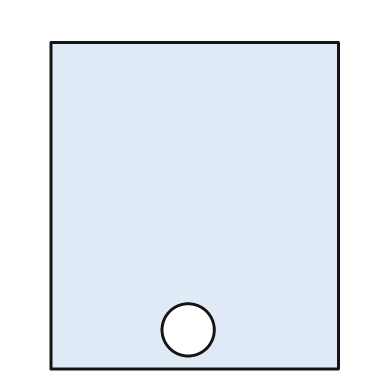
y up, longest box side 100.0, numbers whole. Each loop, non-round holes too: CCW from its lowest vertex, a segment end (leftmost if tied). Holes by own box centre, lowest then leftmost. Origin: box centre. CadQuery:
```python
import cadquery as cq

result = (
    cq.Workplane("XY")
    .moveTo(-44.0, -50.0)
    .lineTo(44.0, -50.0)
    .lineTo(44.0, 50.0)
    .lineTo(-44.0, 50.0)
    .close()
    .moveTo(-2.0, -38.0)
    .circle(8.0)
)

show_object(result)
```